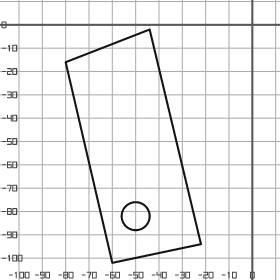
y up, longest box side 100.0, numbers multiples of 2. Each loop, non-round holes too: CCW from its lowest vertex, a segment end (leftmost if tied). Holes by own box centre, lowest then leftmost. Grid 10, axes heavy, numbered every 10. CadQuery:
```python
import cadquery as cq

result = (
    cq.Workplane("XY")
    .moveTo(-60.0, -102.0)
    .lineTo(-22.0, -94.0)
    .lineTo(-44.0, -2.0)
    .lineTo(-80.0, -16.0)
    .close()
    .moveTo(-50.0, -82.0)
    .circle(6.0)
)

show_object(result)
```